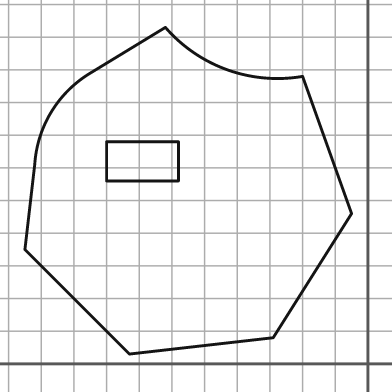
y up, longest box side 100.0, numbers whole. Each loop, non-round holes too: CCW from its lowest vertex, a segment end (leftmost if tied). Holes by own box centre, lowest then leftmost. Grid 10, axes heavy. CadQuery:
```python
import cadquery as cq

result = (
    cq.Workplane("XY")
    .moveTo(-73.0, 3.0)
    .lineTo(-29.0, 8.0)
    .lineTo(-5.0, 46.0)
    .lineTo(-20.0, 88.0)
    .threePointArc((-43.0, 90.0), (-62.0, 103.0))
    .lineTo(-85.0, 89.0)
    .threePointArc((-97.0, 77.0), (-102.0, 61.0))
    .lineTo(-105.0, 35.0)
    .close()
    .moveTo(-80.0, 56.0)
    .lineTo(-58.0, 56.0)
    .lineTo(-58.0, 68.0)
    .lineTo(-80.0, 68.0)
    .close()
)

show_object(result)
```